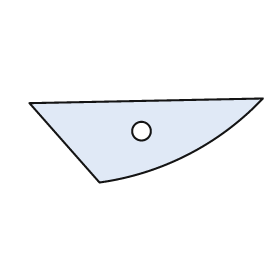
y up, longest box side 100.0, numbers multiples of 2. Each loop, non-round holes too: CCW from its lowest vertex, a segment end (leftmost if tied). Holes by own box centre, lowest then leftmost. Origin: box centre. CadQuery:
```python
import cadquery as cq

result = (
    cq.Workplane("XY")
    .moveTo(-20.0, -18.0)
    .threePointArc((18.0, -6.0), (50.0, 18.0))
    .lineTo(-50.0, 16.0)
    .close()
    .moveTo(-2.0, 4.0)
    .circle(4.0)
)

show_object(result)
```